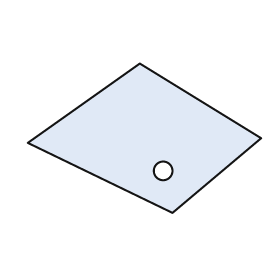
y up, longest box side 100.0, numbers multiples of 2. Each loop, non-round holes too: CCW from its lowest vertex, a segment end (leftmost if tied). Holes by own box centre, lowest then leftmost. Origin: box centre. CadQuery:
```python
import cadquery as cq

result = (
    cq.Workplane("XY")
    .moveTo(12.0, -32.0)
    .lineTo(50.0, 0.0)
    .lineTo(-2.0, 32.0)
    .lineTo(-50.0, -2.0)
    .close()
    .moveTo(8.0, -14.0)
    .circle(4.0)
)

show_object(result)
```